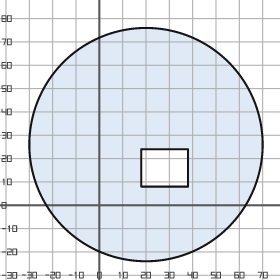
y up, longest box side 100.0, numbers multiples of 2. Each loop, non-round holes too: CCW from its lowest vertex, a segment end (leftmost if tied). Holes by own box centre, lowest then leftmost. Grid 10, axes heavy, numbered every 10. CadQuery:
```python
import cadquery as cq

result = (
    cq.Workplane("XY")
    .moveTo(20.0, 26.0)
    .circle(50.0)
    .moveTo(18.0, 8.0)
    .lineTo(38.0, 8.0)
    .lineTo(38.0, 24.0)
    .lineTo(18.0, 24.0)
    .close()
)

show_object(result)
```